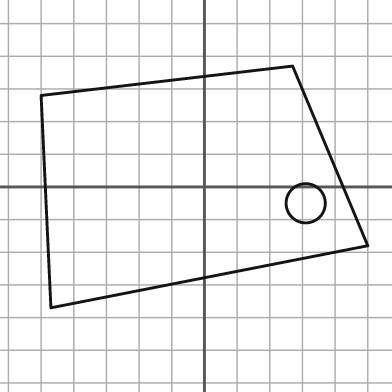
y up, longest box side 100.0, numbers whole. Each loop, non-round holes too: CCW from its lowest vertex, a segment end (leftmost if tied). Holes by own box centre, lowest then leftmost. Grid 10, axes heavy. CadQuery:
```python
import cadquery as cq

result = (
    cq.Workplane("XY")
    .moveTo(-47.0, -37.0)
    .lineTo(50.0, -18.0)
    .lineTo(27.0, 37.0)
    .lineTo(-50.0, 28.0)
    .close()
    .moveTo(31.0, -5.0)
    .circle(6.0)
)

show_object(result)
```